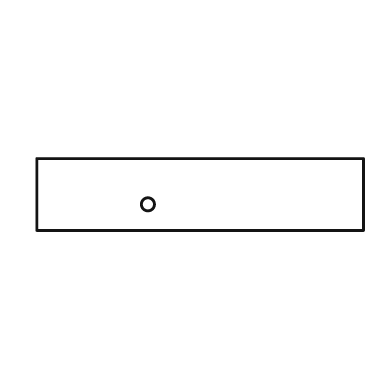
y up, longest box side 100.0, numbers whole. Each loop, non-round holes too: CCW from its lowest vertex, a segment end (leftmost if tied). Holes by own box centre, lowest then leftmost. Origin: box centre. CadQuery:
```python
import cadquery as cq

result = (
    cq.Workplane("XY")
    .moveTo(-50.0, -11.0)
    .lineTo(50.0, -11.0)
    .lineTo(50.0, 11.0)
    .lineTo(-50.0, 11.0)
    .close()
    .moveTo(-16.0, -3.0)
    .circle(2.0)
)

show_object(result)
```